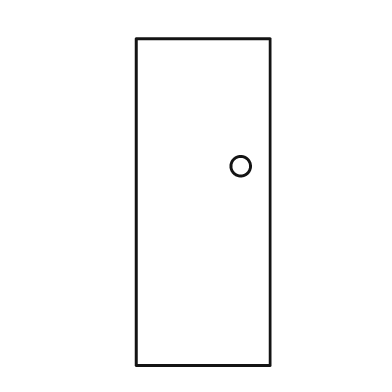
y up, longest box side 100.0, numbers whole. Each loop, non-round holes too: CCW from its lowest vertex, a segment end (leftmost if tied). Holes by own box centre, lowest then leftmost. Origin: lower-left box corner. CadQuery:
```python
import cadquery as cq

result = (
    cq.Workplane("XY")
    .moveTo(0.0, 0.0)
    .lineTo(41.0, 0.0)
    .lineTo(41.0, 100.0)
    .lineTo(0.0, 100.0)
    .close()
    .moveTo(32.0, 61.0)
    .circle(3.0)
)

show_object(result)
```